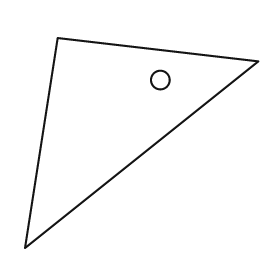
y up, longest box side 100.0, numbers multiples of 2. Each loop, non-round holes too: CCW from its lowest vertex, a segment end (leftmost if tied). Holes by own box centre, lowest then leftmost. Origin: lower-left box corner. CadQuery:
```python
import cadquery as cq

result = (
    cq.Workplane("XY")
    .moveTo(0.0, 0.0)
    .lineTo(100.0, 80.0)
    .lineTo(14.0, 90.0)
    .close()
    .moveTo(58.0, 72.0)
    .circle(4.0)
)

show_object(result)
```